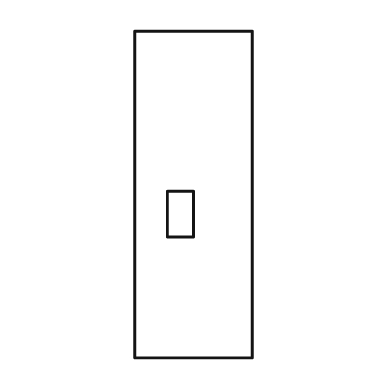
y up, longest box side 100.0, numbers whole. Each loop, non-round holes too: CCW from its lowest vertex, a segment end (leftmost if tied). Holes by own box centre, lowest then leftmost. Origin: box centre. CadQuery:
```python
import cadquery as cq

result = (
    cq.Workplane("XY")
    .moveTo(-18.0, -50.0)
    .lineTo(18.0, -50.0)
    .lineTo(18.0, 50.0)
    .lineTo(-18.0, 50.0)
    .close()
    .moveTo(-8.0, -13.0)
    .lineTo(0.0, -13.0)
    .lineTo(0.0, 1.0)
    .lineTo(-8.0, 1.0)
    .close()
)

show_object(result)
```